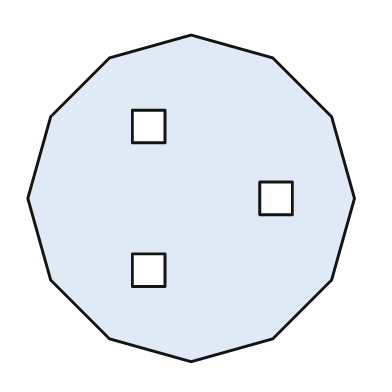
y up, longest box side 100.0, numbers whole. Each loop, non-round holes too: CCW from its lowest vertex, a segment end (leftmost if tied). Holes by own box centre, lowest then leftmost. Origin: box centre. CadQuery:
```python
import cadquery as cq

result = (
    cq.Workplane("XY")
    .moveTo(0.0, -50.0)
    .lineTo(25.0, -43.0)
    .lineTo(43.0, -25.0)
    .lineTo(50.0, 0.0)
    .lineTo(43.0, 25.0)
    .lineTo(25.0, 43.0)
    .lineTo(0.0, 50.0)
    .lineTo(-25.0, 43.0)
    .lineTo(-43.0, 25.0)
    .lineTo(-50.0, 0.0)
    .lineTo(-43.0, -25.0)
    .lineTo(-25.0, -43.0)
    .close()
    .moveTo(-18.0, -27.0)
    .lineTo(-8.0, -27.0)
    .lineTo(-8.0, -17.0)
    .lineTo(-18.0, -17.0)
    .close()
    .moveTo(21.0, -5.0)
    .lineTo(31.0, -5.0)
    .lineTo(31.0, 5.0)
    .lineTo(21.0, 5.0)
    .close()
    .moveTo(-18.0, 17.0)
    .lineTo(-8.0, 17.0)
    .lineTo(-8.0, 27.0)
    .lineTo(-18.0, 27.0)
    .close()
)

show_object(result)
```